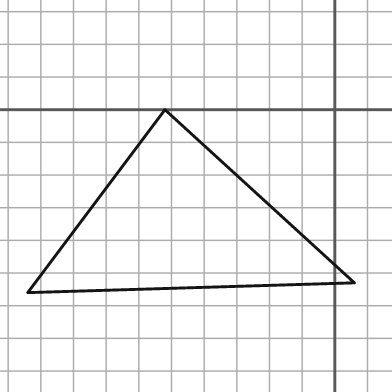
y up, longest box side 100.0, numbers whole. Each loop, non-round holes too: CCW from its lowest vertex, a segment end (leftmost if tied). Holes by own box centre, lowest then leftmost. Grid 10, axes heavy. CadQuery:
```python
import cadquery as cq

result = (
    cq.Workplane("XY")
    .moveTo(-94.0, -56.0)
    .lineTo(6.0, -53.0)
    .lineTo(-52.0, 0.0)
    .close()
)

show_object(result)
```